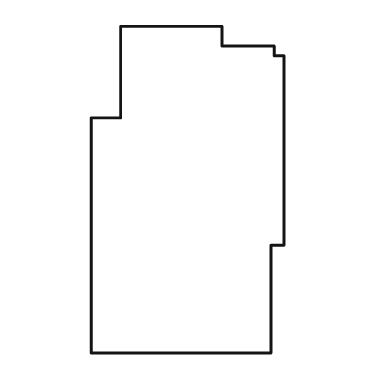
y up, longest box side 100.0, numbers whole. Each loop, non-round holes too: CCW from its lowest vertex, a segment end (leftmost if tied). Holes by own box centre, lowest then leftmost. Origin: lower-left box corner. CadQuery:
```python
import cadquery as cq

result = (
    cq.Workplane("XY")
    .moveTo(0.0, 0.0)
    .lineTo(55.0, 0.0)
    .lineTo(55.0, 33.0)
    .lineTo(59.0, 33.0)
    .lineTo(59.0, 91.0)
    .lineTo(56.0, 91.0)
    .lineTo(56.0, 94.0)
    .lineTo(40.0, 94.0)
    .lineTo(40.0, 100.0)
    .lineTo(9.0, 100.0)
    .lineTo(9.0, 72.0)
    .lineTo(0.0, 72.0)
    .close()
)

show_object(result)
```